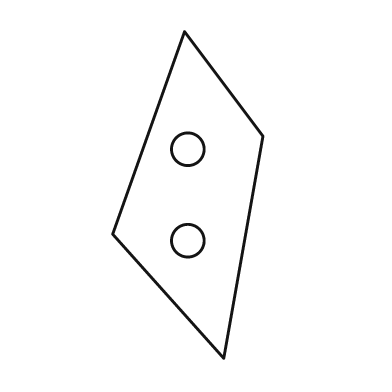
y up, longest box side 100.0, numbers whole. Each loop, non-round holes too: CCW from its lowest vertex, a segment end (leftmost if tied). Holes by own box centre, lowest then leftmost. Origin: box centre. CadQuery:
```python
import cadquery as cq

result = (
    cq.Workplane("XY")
    .moveTo(11.0, -50.0)
    .lineTo(23.0, 18.0)
    .lineTo(-1.0, 50.0)
    .lineTo(-23.0, -12.0)
    .close()
    .moveTo(0.0, -14.0)
    .circle(5.0)
    .moveTo(0.0, 14.0)
    .circle(5.0)
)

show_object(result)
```